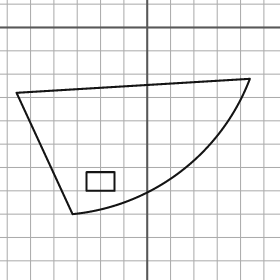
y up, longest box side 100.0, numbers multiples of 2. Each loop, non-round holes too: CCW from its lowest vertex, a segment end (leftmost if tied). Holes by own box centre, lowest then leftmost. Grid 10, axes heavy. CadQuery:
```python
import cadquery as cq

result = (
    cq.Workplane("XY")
    .moveTo(-32.0, -80.0)
    .threePointArc((14.0, -62.0), (44.0, -22.0))
    .lineTo(-56.0, -28.0)
    .close()
    .moveTo(-26.0, -70.0)
    .lineTo(-14.0, -70.0)
    .lineTo(-14.0, -62.0)
    .lineTo(-26.0, -62.0)
    .close()
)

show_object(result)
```